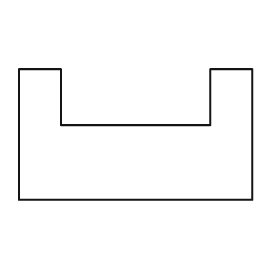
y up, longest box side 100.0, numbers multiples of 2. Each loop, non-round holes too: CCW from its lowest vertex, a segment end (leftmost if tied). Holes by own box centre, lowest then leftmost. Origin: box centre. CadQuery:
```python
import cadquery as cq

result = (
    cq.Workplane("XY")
    .moveTo(-50.0, -28.0)
    .lineTo(50.0, -28.0)
    .lineTo(50.0, 28.0)
    .lineTo(32.0, 28.0)
    .lineTo(32.0, 4.0)
    .lineTo(-32.0, 4.0)
    .lineTo(-32.0, 28.0)
    .lineTo(-50.0, 28.0)
    .close()
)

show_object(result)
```